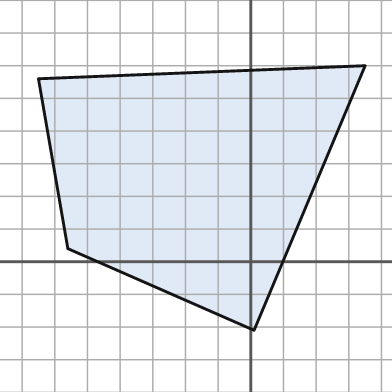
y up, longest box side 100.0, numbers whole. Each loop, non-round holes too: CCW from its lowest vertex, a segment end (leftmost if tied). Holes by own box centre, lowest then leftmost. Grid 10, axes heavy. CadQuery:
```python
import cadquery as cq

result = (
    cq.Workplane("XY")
    .moveTo(1.0, -21.0)
    .lineTo(35.0, 60.0)
    .lineTo(-65.0, 56.0)
    .lineTo(-56.0, 4.0)
    .close()
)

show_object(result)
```